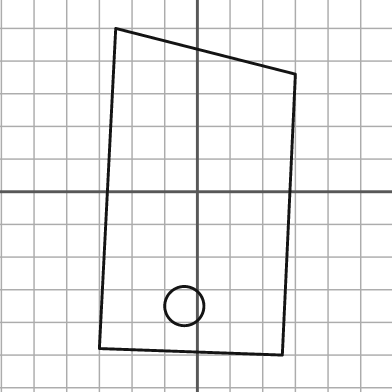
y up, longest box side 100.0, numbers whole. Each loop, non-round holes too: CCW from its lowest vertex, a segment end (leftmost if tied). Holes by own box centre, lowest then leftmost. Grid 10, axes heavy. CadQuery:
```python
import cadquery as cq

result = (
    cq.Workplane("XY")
    .moveTo(26.0, -50.0)
    .lineTo(30.0, 36.0)
    .lineTo(-25.0, 50.0)
    .lineTo(-30.0, -48.0)
    .close()
    .moveTo(-4.0, -35.0)
    .circle(6.0)
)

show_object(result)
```